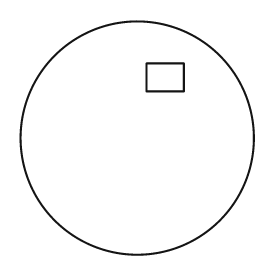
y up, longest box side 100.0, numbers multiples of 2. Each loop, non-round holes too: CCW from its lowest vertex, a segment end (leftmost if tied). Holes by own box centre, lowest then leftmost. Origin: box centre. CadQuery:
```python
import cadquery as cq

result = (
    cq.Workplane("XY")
    .moveTo(0.0, 0.0)
    .circle(50.0)
    .moveTo(4.0, 20.0)
    .lineTo(20.0, 20.0)
    .lineTo(20.0, 32.0)
    .lineTo(4.0, 32.0)
    .close()
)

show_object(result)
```